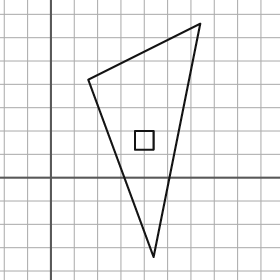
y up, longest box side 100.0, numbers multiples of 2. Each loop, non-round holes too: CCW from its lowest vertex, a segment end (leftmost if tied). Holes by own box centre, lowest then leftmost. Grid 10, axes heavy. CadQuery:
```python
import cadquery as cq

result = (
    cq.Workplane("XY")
    .moveTo(44.0, -34.0)
    .lineTo(64.0, 66.0)
    .lineTo(16.0, 42.0)
    .close()
    .moveTo(36.0, 12.0)
    .lineTo(44.0, 12.0)
    .lineTo(44.0, 20.0)
    .lineTo(36.0, 20.0)
    .close()
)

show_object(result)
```